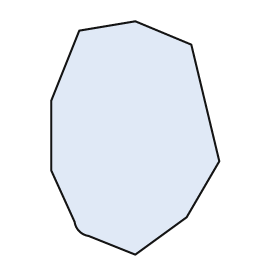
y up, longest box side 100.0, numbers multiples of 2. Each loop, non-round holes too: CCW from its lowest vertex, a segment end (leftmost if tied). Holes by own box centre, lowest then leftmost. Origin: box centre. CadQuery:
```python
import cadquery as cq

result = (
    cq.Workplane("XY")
    .moveTo(0.0, -50.0)
    .lineTo(22.0, -34.0)
    .lineTo(36.0, -10.0)
    .lineTo(24.0, 40.0)
    .lineTo(0.0, 50.0)
    .lineTo(-24.0, 46.0)
    .lineTo(-36.0, 16.0)
    .lineTo(-36.0, -14.0)
    .lineTo(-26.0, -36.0)
    .threePointArc((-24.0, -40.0), (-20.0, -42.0))
    .close()
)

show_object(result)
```